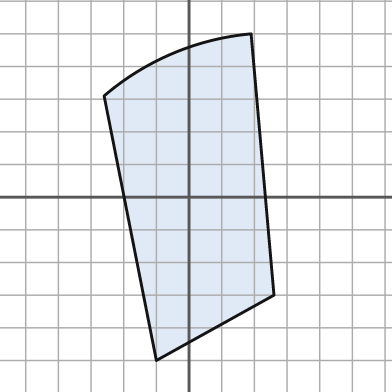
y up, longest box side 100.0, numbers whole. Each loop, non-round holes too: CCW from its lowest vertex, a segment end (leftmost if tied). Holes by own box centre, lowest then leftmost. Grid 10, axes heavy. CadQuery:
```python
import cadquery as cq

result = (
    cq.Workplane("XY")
    .moveTo(-10.0, -50.0)
    .lineTo(26.0, -30.0)
    .lineTo(19.0, 50.0)
    .threePointArc((-5.0, 44.0), (-26.0, 31.0))
    .close()
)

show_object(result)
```